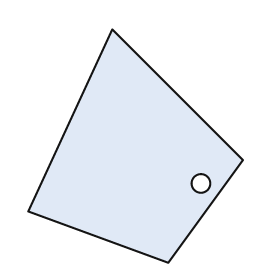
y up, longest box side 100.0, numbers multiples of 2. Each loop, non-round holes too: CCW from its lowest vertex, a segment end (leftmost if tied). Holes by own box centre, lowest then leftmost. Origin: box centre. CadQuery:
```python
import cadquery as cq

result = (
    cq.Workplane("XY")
    .moveTo(14.0, -50.0)
    .lineTo(46.0, -6.0)
    .lineTo(-10.0, 50.0)
    .lineTo(-46.0, -28.0)
    .close()
    .moveTo(28.0, -16.0)
    .circle(4.0)
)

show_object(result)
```